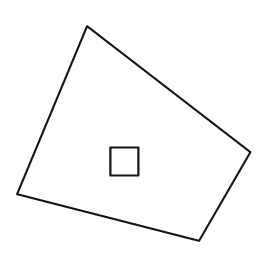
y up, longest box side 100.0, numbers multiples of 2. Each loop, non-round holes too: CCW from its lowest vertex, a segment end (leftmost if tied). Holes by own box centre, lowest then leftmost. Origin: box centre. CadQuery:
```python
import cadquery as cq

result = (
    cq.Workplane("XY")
    .moveTo(28.0, -46.0)
    .lineTo(50.0, -8.0)
    .lineTo(-20.0, 46.0)
    .lineTo(-50.0, -26.0)
    .close()
    .moveTo(-10.0, -18.0)
    .lineTo(2.0, -18.0)
    .lineTo(2.0, -6.0)
    .lineTo(-10.0, -6.0)
    .close()
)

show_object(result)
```